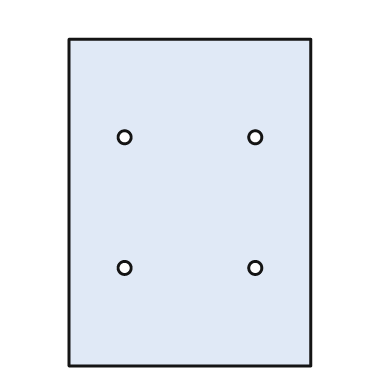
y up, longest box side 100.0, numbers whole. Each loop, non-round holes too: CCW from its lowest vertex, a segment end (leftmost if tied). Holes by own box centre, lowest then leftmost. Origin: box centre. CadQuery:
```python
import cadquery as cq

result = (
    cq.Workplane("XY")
    .moveTo(-37.0, -50.0)
    .lineTo(37.0, -50.0)
    .lineTo(37.0, 50.0)
    .lineTo(-37.0, 50.0)
    .close()
    .moveTo(-20.0, -20.0)
    .circle(2.0)
    .moveTo(20.0, -20.0)
    .circle(2.0)
    .moveTo(-20.0, 20.0)
    .circle(2.0)
    .moveTo(20.0, 20.0)
    .circle(2.0)
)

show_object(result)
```